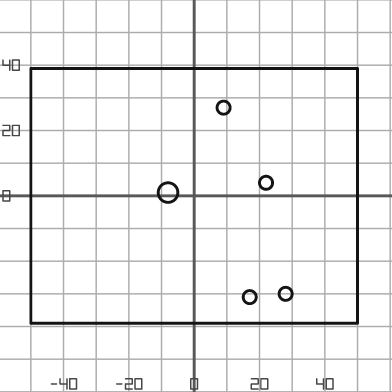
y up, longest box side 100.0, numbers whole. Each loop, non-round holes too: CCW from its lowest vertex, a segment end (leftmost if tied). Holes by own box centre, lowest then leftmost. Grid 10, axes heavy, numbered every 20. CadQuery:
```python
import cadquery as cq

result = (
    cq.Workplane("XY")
    .moveTo(-50.0, -39.0)
    .lineTo(50.0, -39.0)
    .lineTo(50.0, 39.0)
    .lineTo(-50.0, 39.0)
    .close()
    .moveTo(17.0, -31.0)
    .circle(2.0)
    .moveTo(28.0, -30.0)
    .circle(2.0)
    .moveTo(-8.0, 1.0)
    .circle(3.0)
    .moveTo(22.0, 4.0)
    .circle(2.0)
    .moveTo(9.0, 27.0)
    .circle(2.0)
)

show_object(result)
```